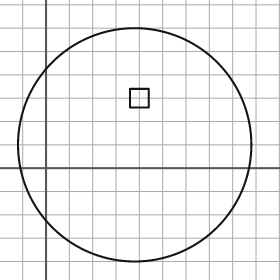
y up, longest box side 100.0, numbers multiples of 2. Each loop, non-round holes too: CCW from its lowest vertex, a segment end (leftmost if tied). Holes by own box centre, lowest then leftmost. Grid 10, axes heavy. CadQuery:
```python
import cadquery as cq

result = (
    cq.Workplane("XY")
    .moveTo(38.0, 10.0)
    .circle(50.0)
    .moveTo(36.0, 26.0)
    .lineTo(44.0, 26.0)
    .lineTo(44.0, 34.0)
    .lineTo(36.0, 34.0)
    .close()
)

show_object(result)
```